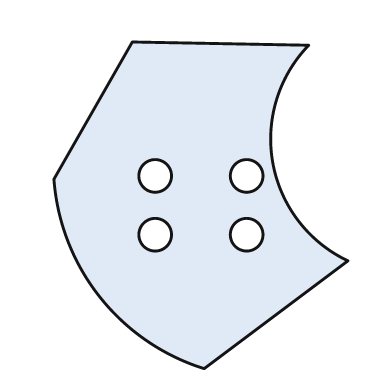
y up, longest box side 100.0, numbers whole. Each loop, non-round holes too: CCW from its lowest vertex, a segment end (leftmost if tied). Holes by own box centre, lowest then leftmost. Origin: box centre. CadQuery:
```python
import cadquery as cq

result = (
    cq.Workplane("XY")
    .moveTo(1.0, -50.0)
    .lineTo(45.0, -17.0)
    .threePointArc((22.0, 13.0), (33.0, 49.0))
    .lineTo(-21.0, 50.0)
    .lineTo(-45.0, 8.0)
    .threePointArc((-31.0, -28.0), (1.0, -50.0))
    .close()
    .moveTo(-14.0, -9.0)
    .circle(5.0)
    .moveTo(14.0, -9.0)
    .circle(5.0)
    .moveTo(-14.0, 9.0)
    .circle(5.0)
    .moveTo(14.0, 9.0)
    .circle(5.0)
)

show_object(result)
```